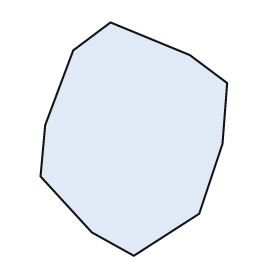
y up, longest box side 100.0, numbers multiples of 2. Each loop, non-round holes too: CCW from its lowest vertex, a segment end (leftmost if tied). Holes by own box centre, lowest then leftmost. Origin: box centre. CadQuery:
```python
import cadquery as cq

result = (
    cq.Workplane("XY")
    .moveTo(0.0, -50.0)
    .lineTo(28.0, -32.0)
    .lineTo(38.0, -2.0)
    .lineTo(40.0, 24.0)
    .lineTo(24.0, 36.0)
    .lineTo(-10.0, 50.0)
    .lineTo(-26.0, 38.0)
    .lineTo(-38.0, 6.0)
    .lineTo(-40.0, -16.0)
    .lineTo(-18.0, -40.0)
    .close()
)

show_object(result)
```